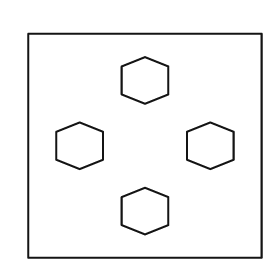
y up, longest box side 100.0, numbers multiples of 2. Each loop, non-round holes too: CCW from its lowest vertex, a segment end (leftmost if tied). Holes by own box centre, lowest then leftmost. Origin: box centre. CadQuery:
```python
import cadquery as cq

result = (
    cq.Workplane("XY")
    .moveTo(-50.0, -48.0)
    .lineTo(50.0, -48.0)
    .lineTo(50.0, 48.0)
    .lineTo(-50.0, 48.0)
    .close()
    .moveTo(0.0, -38.0)
    .lineTo(10.0, -34.0)
    .lineTo(10.0, -22.0)
    .lineTo(0.0, -18.0)
    .lineTo(-10.0, -22.0)
    .lineTo(-10.0, -34.0)
    .close()
    .moveTo(-28.0, -10.0)
    .lineTo(-18.0, -6.0)
    .lineTo(-18.0, 6.0)
    .lineTo(-28.0, 10.0)
    .lineTo(-38.0, 6.0)
    .lineTo(-38.0, -6.0)
    .close()
    .moveTo(28.0, -10.0)
    .lineTo(38.0, -6.0)
    .lineTo(38.0, 6.0)
    .lineTo(28.0, 10.0)
    .lineTo(18.0, 6.0)
    .lineTo(18.0, -6.0)
    .close()
    .moveTo(0.0, 18.0)
    .lineTo(10.0, 22.0)
    .lineTo(10.0, 34.0)
    .lineTo(0.0, 38.0)
    .lineTo(-10.0, 34.0)
    .lineTo(-10.0, 22.0)
    .close()
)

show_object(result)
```